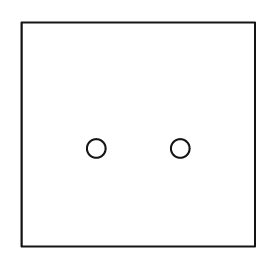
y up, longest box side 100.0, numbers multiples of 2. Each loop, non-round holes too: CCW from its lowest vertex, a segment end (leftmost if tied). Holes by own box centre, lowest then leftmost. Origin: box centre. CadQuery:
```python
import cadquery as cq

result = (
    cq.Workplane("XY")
    .moveTo(-50.0, -48.0)
    .lineTo(50.0, -48.0)
    .lineTo(50.0, 48.0)
    .lineTo(-50.0, 48.0)
    .close()
    .moveTo(-18.0, -6.0)
    .circle(4.0)
    .moveTo(18.0, -6.0)
    .circle(4.0)
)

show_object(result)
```